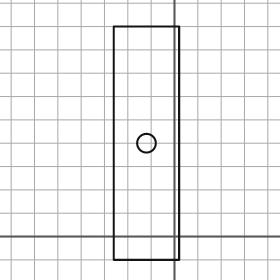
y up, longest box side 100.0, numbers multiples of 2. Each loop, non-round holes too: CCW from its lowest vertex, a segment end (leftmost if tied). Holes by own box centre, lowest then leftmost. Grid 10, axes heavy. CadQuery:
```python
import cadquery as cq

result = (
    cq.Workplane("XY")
    .moveTo(-26.0, -10.0)
    .lineTo(2.0, -10.0)
    .lineTo(2.0, 90.0)
    .lineTo(-26.0, 90.0)
    .close()
    .moveTo(-12.0, 40.0)
    .circle(4.0)
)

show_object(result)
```